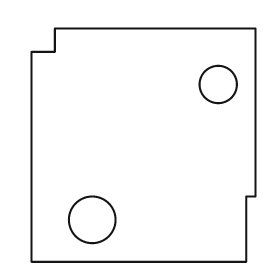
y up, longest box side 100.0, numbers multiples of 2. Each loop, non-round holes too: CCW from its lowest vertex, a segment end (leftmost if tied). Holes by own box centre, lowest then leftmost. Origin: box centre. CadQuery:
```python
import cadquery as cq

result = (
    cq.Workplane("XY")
    .moveTo(-48.0, -50.0)
    .lineTo(44.0, -50.0)
    .lineTo(44.0, -22.0)
    .lineTo(48.0, -22.0)
    .lineTo(48.0, 50.0)
    .lineTo(-38.0, 50.0)
    .lineTo(-38.0, 40.0)
    .lineTo(-48.0, 40.0)
    .close()
    .moveTo(-22.0, -32.0)
    .circle(10.0)
    .moveTo(32.0, 26.0)
    .circle(8.0)
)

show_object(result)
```